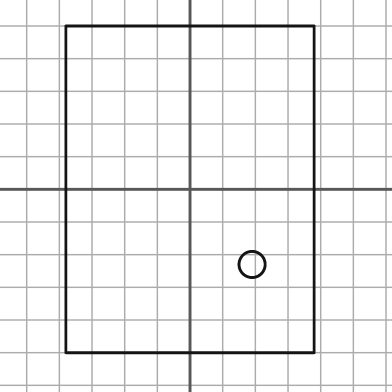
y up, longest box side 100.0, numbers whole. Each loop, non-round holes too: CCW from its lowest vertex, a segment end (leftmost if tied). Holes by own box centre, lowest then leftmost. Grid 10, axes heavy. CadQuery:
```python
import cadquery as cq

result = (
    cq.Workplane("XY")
    .moveTo(-38.0, -50.0)
    .lineTo(38.0, -50.0)
    .lineTo(38.0, 50.0)
    .lineTo(-38.0, 50.0)
    .close()
    .moveTo(19.0, -23.0)
    .circle(4.0)
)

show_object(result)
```